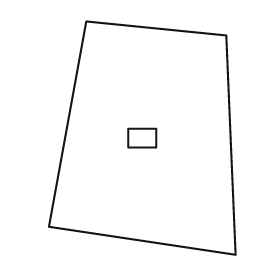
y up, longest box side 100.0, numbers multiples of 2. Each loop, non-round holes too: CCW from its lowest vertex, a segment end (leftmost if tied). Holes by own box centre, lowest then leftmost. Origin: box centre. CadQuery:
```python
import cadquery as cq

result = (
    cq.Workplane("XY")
    .moveTo(40.0, -50.0)
    .lineTo(36.0, 44.0)
    .lineTo(-24.0, 50.0)
    .lineTo(-40.0, -38.0)
    .close()
    .moveTo(-6.0, -4.0)
    .lineTo(6.0, -4.0)
    .lineTo(6.0, 4.0)
    .lineTo(-6.0, 4.0)
    .close()
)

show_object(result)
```